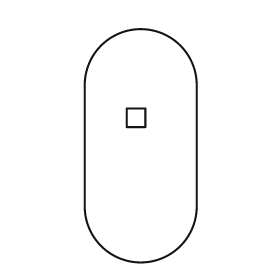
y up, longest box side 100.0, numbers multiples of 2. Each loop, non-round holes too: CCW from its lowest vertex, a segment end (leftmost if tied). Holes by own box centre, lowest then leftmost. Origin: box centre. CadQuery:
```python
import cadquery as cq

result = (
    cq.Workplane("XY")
    .moveTo(-24.0, -26.0)
    .threePointArc((0.0, -50.0), (24.0, -26.0))
    .lineTo(24.0, 26.0)
    .threePointArc((0.0, 50.0), (-24.0, 26.0))
    .close()
    .moveTo(-6.0, 8.0)
    .lineTo(2.0, 8.0)
    .lineTo(2.0, 16.0)
    .lineTo(-6.0, 16.0)
    .close()
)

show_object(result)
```